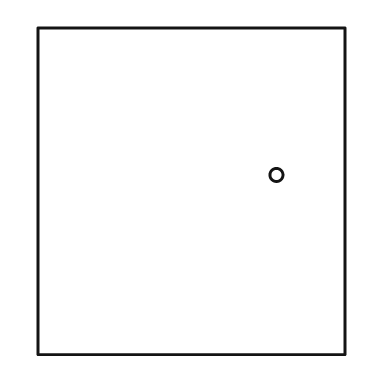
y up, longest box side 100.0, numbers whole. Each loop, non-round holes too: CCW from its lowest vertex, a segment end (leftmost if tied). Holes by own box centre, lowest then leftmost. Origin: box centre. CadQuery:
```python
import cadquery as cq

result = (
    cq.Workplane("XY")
    .moveTo(-47.0, -50.0)
    .lineTo(47.0, -50.0)
    .lineTo(47.0, 50.0)
    .lineTo(-47.0, 50.0)
    .close()
    .moveTo(26.0, 5.0)
    .circle(2.0)
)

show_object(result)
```